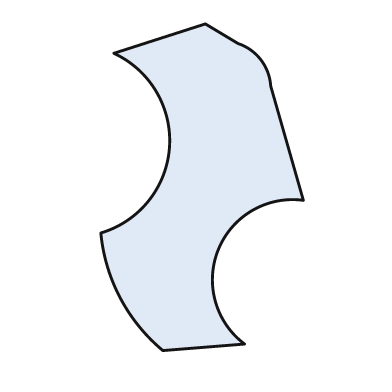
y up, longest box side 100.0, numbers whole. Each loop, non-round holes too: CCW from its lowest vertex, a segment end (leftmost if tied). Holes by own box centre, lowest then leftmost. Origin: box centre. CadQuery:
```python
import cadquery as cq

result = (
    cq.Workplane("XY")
    .moveTo(-12.0, -50.0)
    .lineTo(13.0, -48.0)
    .threePointArc((5.0, -19.0), (31.0, -4.0))
    .lineTo(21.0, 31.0)
    .threePointArc((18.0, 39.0), (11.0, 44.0))
    .lineTo(1.0, 50.0)
    .lineTo(-27.0, 41.0)
    .threePointArc((-10.0, 12.0), (-31.0, -14.0))
    .threePointArc((-25.0, -34.0), (-12.0, -50.0))
    .close()
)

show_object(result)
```